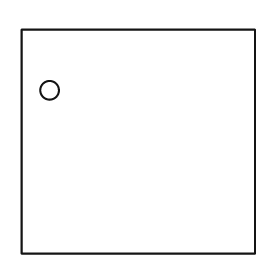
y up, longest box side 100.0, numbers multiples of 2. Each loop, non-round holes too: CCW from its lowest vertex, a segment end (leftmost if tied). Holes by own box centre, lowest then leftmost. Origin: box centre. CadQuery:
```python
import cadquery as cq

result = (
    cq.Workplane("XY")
    .moveTo(-50.0, -48.0)
    .lineTo(50.0, -48.0)
    .lineTo(50.0, 48.0)
    .lineTo(-50.0, 48.0)
    .close()
    .moveTo(-38.0, 22.0)
    .circle(4.0)
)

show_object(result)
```